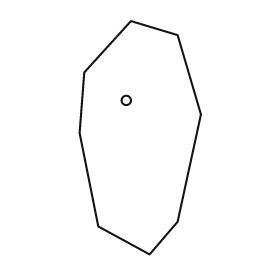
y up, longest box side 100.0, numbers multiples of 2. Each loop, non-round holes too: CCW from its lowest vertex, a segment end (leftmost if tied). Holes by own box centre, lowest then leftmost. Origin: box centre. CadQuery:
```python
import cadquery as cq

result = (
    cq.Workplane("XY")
    .moveTo(4.0, -50.0)
    .lineTo(16.0, -36.0)
    .lineTo(26.0, 10.0)
    .lineTo(16.0, 44.0)
    .lineTo(-4.0, 50.0)
    .lineTo(-24.0, 28.0)
    .lineTo(-26.0, 2.0)
    .lineTo(-18.0, -38.0)
    .close()
    .moveTo(-6.0, 16.0)
    .circle(2.0)
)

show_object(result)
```